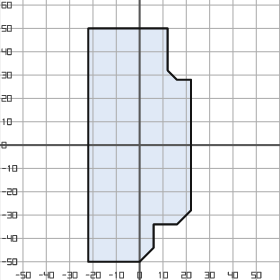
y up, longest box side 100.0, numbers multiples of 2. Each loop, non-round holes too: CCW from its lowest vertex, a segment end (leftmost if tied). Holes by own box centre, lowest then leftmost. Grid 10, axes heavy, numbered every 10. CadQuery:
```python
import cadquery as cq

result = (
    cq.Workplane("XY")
    .moveTo(-22.0, -50.0)
    .lineTo(0.0, -50.0)
    .lineTo(6.0, -44.0)
    .lineTo(6.0, -34.0)
    .lineTo(16.0, -34.0)
    .lineTo(22.0, -28.0)
    .lineTo(22.0, 28.0)
    .lineTo(16.0, 28.0)
    .lineTo(12.0, 32.0)
    .lineTo(12.0, 50.0)
    .lineTo(-22.0, 50.0)
    .close()
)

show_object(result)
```